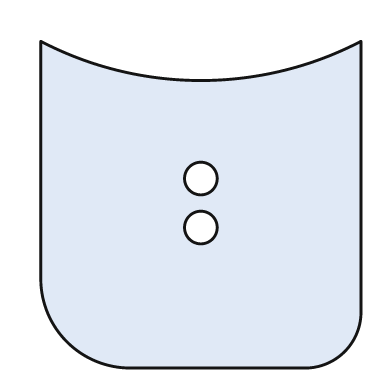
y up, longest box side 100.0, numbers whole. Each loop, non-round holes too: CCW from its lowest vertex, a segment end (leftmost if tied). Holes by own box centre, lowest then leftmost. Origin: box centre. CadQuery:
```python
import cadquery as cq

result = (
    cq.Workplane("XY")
    .moveTo(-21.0, -50.0)
    .lineTo(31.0, -50.0)
    .threePointArc((44.0, -45.0), (49.0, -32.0))
    .lineTo(49.0, 50.0)
    .threePointArc((0.0, 38.0), (-49.0, 50.0))
    .lineTo(-49.0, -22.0)
    .threePointArc((-41.0, -42.0), (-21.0, -50.0))
    .close()
    .moveTo(0.0, -7.0)
    .circle(5.0)
    .moveTo(0.0, 8.0)
    .circle(5.0)
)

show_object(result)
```